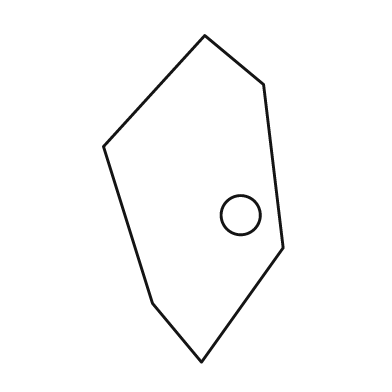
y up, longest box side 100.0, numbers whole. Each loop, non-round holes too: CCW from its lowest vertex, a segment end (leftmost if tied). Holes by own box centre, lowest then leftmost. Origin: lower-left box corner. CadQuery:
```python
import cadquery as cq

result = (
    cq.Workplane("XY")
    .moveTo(30.0, 0.0)
    .lineTo(55.0, 35.0)
    .lineTo(49.0, 85.0)
    .lineTo(31.0, 100.0)
    .lineTo(0.0, 66.0)
    .lineTo(15.0, 18.0)
    .close()
    .moveTo(42.0, 45.0)
    .circle(6.0)
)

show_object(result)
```